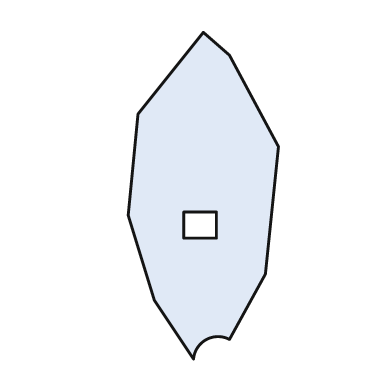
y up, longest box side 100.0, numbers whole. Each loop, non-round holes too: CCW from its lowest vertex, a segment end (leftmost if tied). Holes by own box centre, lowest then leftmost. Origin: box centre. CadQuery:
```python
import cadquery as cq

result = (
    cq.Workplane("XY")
    .moveTo(-3.0, -50.0)
    .threePointArc((1.0, -44.0), (8.0, -44.0))
    .lineTo(19.0, -24.0)
    .lineTo(23.0, 15.0)
    .lineTo(8.0, 43.0)
    .lineTo(0.0, 50.0)
    .lineTo(-20.0, 25.0)
    .lineTo(-23.0, -6.0)
    .lineTo(-15.0, -32.0)
    .close()
    .moveTo(-6.0, -13.0)
    .lineTo(4.0, -13.0)
    .lineTo(4.0, -5.0)
    .lineTo(-6.0, -5.0)
    .close()
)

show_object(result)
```